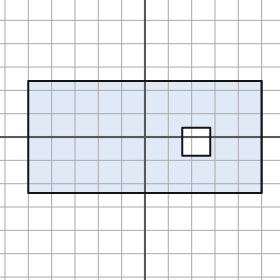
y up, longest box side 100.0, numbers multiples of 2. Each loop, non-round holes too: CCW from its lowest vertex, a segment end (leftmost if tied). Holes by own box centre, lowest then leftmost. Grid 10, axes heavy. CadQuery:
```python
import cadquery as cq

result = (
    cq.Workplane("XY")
    .moveTo(-50.0, -24.0)
    .lineTo(50.0, -24.0)
    .lineTo(50.0, 24.0)
    .lineTo(-50.0, 24.0)
    .close()
    .moveTo(16.0, -8.0)
    .lineTo(28.0, -8.0)
    .lineTo(28.0, 4.0)
    .lineTo(16.0, 4.0)
    .close()
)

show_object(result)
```